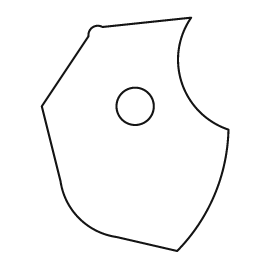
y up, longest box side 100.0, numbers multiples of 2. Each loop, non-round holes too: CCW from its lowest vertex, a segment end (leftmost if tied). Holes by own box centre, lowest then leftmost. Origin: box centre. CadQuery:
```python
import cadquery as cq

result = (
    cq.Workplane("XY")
    .moveTo(18.0, -50.0)
    .threePointArc((34.0, -26.0), (40.0, 2.0))
    .threePointArc((20.0, 22.0), (24.0, 50.0))
    .lineTo(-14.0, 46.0)
    .threePointArc((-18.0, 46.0), (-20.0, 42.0))
    .lineTo(-40.0, 12.0)
    .lineTo(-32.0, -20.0)
    .threePointArc((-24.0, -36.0), (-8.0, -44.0))
    .close()
    .moveTo(0.0, 12.0)
    .circle(8.0)
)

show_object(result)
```